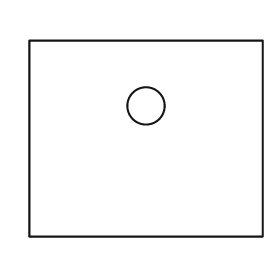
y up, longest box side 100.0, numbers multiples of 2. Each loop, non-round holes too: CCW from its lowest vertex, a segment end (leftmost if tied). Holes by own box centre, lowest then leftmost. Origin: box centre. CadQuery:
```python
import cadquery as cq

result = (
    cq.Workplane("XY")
    .moveTo(-50.0, -42.0)
    .lineTo(50.0, -42.0)
    .lineTo(50.0, 42.0)
    .lineTo(-50.0, 42.0)
    .close()
    .moveTo(0.0, 14.0)
    .circle(8.0)
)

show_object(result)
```